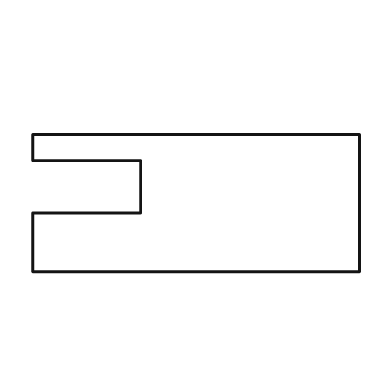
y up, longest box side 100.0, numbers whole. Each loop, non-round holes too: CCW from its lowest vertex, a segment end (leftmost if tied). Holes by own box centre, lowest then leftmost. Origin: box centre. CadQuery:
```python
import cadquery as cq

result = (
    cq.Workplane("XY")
    .moveTo(-50.0, -21.0)
    .lineTo(50.0, -21.0)
    .lineTo(50.0, 21.0)
    .lineTo(-50.0, 21.0)
    .lineTo(-50.0, 13.0)
    .lineTo(-17.0, 13.0)
    .lineTo(-17.0, -3.0)
    .lineTo(-50.0, -3.0)
    .close()
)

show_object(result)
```